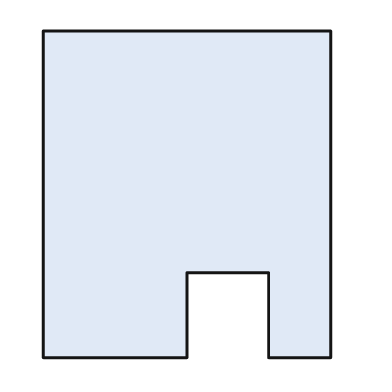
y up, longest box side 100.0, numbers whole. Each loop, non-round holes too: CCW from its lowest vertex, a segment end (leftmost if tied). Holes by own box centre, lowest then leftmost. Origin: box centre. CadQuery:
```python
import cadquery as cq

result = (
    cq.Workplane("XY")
    .moveTo(-44.0, -50.0)
    .lineTo(0.0, -50.0)
    .lineTo(0.0, -24.0)
    .lineTo(25.0, -24.0)
    .lineTo(25.0, -50.0)
    .lineTo(44.0, -50.0)
    .lineTo(44.0, 50.0)
    .lineTo(-44.0, 50.0)
    .close()
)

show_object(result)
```